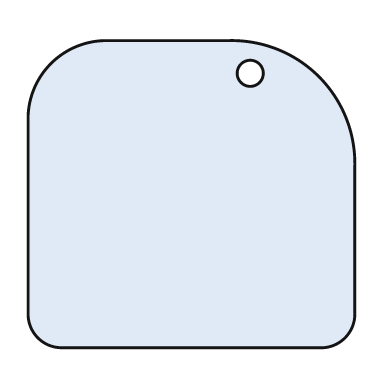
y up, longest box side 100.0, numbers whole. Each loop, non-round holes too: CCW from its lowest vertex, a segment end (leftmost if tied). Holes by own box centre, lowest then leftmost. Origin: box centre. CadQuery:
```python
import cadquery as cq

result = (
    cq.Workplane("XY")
    .moveTo(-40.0, -47.0)
    .lineTo(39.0, -47.0)
    .threePointArc((47.0, -44.0), (50.0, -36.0))
    .lineTo(50.0, 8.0)
    .threePointArc((39.0, 36.0), (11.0, 47.0))
    .lineTo(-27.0, 47.0)
    .threePointArc((-43.0, 40.0), (-50.0, 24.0))
    .lineTo(-50.0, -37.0)
    .threePointArc((-47.0, -44.0), (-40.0, -47.0))
    .close()
    .moveTo(18.0, 37.0)
    .circle(4.0)
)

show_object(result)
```